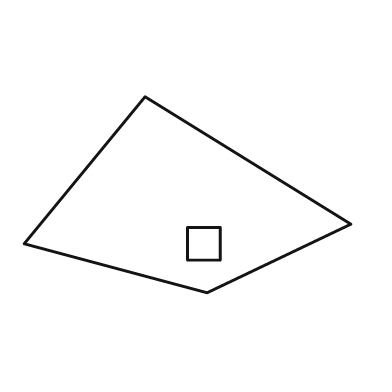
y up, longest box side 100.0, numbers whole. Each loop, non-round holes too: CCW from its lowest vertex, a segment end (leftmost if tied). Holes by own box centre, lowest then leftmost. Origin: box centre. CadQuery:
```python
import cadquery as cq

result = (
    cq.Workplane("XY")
    .moveTo(6.0, -30.0)
    .lineTo(50.0, -9.0)
    .lineTo(-13.0, 30.0)
    .lineTo(-50.0, -15.0)
    .close()
    .moveTo(0.0, -20.0)
    .lineTo(10.0, -20.0)
    .lineTo(10.0, -10.0)
    .lineTo(0.0, -10.0)
    .close()
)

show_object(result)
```